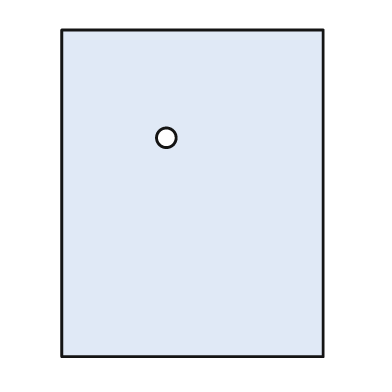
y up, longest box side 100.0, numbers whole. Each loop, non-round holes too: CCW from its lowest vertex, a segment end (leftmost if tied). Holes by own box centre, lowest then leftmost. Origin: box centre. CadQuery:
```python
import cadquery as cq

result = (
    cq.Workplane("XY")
    .moveTo(-40.0, -50.0)
    .lineTo(40.0, -50.0)
    .lineTo(40.0, 50.0)
    .lineTo(-40.0, 50.0)
    .close()
    .moveTo(-8.0, 17.0)
    .circle(3.0)
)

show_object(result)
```